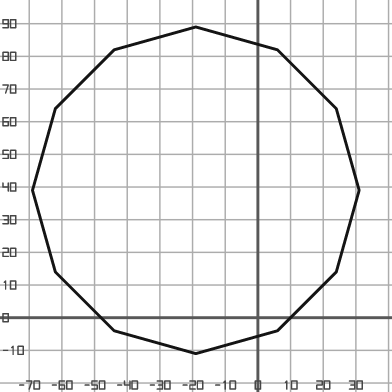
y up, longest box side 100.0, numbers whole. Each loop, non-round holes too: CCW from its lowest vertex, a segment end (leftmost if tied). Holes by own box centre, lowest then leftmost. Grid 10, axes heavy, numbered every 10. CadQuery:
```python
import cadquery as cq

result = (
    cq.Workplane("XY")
    .moveTo(-19.0, -11.0)
    .lineTo(6.0, -4.0)
    .lineTo(24.0, 14.0)
    .lineTo(31.0, 39.0)
    .lineTo(24.0, 64.0)
    .lineTo(6.0, 82.0)
    .lineTo(-19.0, 89.0)
    .lineTo(-44.0, 82.0)
    .lineTo(-62.0, 64.0)
    .lineTo(-69.0, 39.0)
    .lineTo(-62.0, 14.0)
    .lineTo(-44.0, -4.0)
    .close()
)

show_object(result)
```